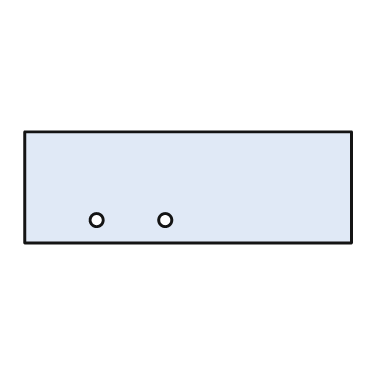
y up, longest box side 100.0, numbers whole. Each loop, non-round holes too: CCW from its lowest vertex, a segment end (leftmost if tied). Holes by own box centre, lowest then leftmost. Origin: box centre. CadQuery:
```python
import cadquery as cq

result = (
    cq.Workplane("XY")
    .moveTo(-50.0, -17.0)
    .lineTo(50.0, -17.0)
    .lineTo(50.0, 17.0)
    .lineTo(-50.0, 17.0)
    .close()
    .moveTo(-28.0, -10.0)
    .circle(2.0)
    .moveTo(-7.0, -10.0)
    .circle(2.0)
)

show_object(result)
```